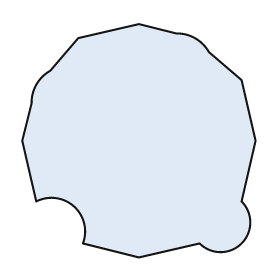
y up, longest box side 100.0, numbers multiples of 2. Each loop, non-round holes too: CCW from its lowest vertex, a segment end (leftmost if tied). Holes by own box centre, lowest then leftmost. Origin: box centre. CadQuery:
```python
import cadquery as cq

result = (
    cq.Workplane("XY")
    .moveTo(0.0, -50.0)
    .lineTo(26.0, -44.0)
    .threePointArc((44.0, -44.0), (44.0, -26.0))
    .lineTo(50.0, 0.0)
    .lineTo(44.0, 26.0)
    .lineTo(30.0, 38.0)
    .threePointArc((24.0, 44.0), (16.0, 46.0))
    .lineTo(0.0, 50.0)
    .lineTo(-26.0, 44.0)
    .lineTo(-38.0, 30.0)
    .threePointArc((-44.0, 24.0), (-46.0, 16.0))
    .lineTo(-50.0, 0.0)
    .lineTo(-44.0, -26.0)
    .threePointArc((-28.0, -28.0), (-24.0, -44.0))
    .close()
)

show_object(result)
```